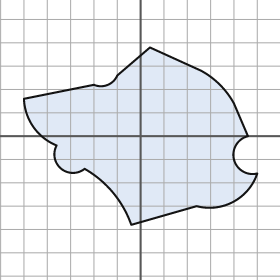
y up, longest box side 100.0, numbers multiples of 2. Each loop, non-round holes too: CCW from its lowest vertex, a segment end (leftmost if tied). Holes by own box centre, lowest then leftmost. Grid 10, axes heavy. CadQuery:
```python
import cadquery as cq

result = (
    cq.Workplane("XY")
    .moveTo(-4.0, -38.0)
    .lineTo(24.0, -30.0)
    .threePointArc((40.0, -28.0), (50.0, -16.0))
    .threePointArc((40.0, -10.0), (46.0, 0.0))
    .lineTo(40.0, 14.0)
    .threePointArc((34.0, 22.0), (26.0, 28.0))
    .lineTo(4.0, 38.0)
    .lineTo(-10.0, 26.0)
    .threePointArc((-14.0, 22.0), (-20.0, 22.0))
    .lineTo(-50.0, 16.0)
    .threePointArc((-46.0, 4.0), (-36.0, -4.0))
    .threePointArc((-34.0, -14.0), (-24.0, -14.0))
    .threePointArc((-12.0, -24.0), (-4.0, -38.0))
    .close()
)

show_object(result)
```